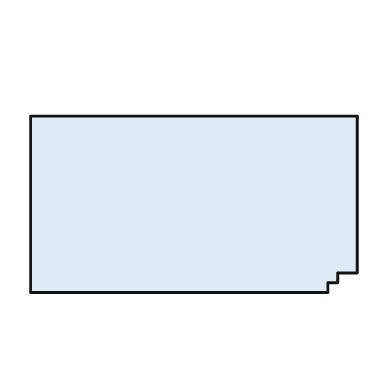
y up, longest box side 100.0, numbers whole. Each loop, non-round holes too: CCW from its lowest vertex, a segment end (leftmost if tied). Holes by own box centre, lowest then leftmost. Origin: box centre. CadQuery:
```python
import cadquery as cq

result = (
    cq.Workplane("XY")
    .moveTo(-50.0, -27.0)
    .lineTo(41.0, -27.0)
    .lineTo(41.0, -24.0)
    .lineTo(44.0, -24.0)
    .lineTo(44.0, -21.0)
    .lineTo(50.0, -21.0)
    .lineTo(50.0, 27.0)
    .lineTo(-50.0, 27.0)
    .close()
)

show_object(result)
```